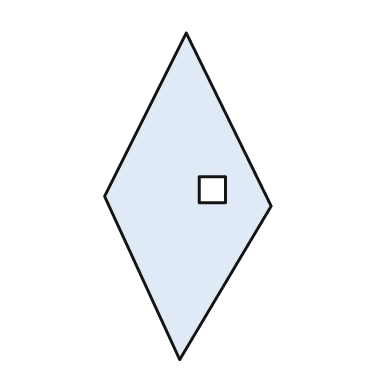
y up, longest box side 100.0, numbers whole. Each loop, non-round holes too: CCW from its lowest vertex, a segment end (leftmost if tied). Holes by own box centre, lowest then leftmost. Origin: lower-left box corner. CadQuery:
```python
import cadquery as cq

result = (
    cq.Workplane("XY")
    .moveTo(23.0, 0.0)
    .lineTo(51.0, 47.0)
    .lineTo(25.0, 100.0)
    .lineTo(0.0, 50.0)
    .close()
    .moveTo(29.0, 48.0)
    .lineTo(37.0, 48.0)
    .lineTo(37.0, 56.0)
    .lineTo(29.0, 56.0)
    .close()
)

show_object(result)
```